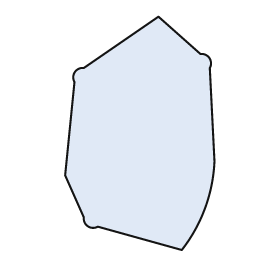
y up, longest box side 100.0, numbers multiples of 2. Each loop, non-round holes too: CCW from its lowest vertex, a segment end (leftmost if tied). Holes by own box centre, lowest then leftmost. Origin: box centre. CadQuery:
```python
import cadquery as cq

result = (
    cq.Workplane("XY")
    .moveTo(18.0, -50.0)
    .threePointArc((28.0, -32.0), (32.0, -12.0))
    .lineTo(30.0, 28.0)
    .threePointArc((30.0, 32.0), (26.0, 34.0))
    .lineTo(8.0, 50.0)
    .lineTo(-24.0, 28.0)
    .threePointArc((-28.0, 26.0), (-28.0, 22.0))
    .lineTo(-32.0, -18.0)
    .lineTo(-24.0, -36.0)
    .threePointArc((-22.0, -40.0), (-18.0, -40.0))
    .close()
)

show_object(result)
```